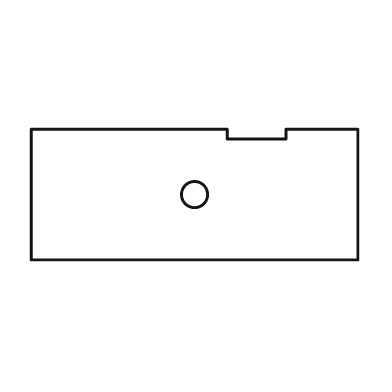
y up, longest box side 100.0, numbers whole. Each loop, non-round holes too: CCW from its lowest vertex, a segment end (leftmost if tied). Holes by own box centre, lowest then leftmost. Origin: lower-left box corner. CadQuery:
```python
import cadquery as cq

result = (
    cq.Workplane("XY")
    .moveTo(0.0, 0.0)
    .lineTo(100.0, 0.0)
    .lineTo(100.0, 40.0)
    .lineTo(78.0, 40.0)
    .lineTo(78.0, 37.0)
    .lineTo(60.0, 37.0)
    .lineTo(60.0, 40.0)
    .lineTo(0.0, 40.0)
    .close()
    .moveTo(50.0, 20.0)
    .circle(4.0)
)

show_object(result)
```